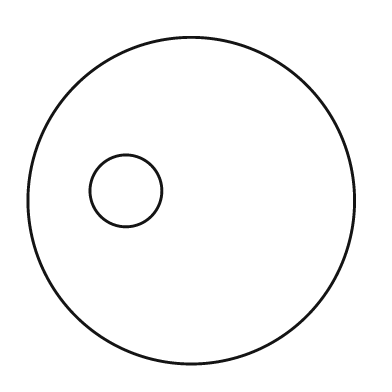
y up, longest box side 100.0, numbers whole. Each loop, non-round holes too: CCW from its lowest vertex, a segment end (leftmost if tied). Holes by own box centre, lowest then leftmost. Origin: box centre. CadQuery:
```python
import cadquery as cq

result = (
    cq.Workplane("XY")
    .moveTo(0.0, 0.0)
    .circle(50.0)
    .moveTo(-20.0, 3.0)
    .circle(11.0)
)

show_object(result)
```